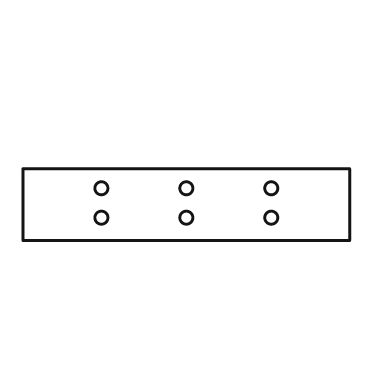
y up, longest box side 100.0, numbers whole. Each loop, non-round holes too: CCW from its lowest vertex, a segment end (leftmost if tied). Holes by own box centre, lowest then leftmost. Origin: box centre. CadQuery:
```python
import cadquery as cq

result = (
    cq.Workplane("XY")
    .moveTo(-50.0, -11.0)
    .lineTo(50.0, -11.0)
    .lineTo(50.0, 11.0)
    .lineTo(-50.0, 11.0)
    .close()
    .moveTo(-26.0, -4.0)
    .circle(2.0)
    .moveTo(0.0, -4.0)
    .circle(2.0)
    .moveTo(26.0, -4.0)
    .circle(2.0)
    .moveTo(-26.0, 5.0)
    .circle(2.0)
    .moveTo(0.0, 5.0)
    .circle(2.0)
    .moveTo(26.0, 5.0)
    .circle(2.0)
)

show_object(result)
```